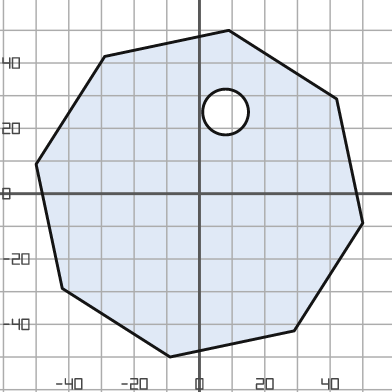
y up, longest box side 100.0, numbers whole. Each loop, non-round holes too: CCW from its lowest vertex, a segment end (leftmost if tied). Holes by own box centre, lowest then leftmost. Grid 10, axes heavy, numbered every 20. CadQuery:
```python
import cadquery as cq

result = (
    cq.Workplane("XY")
    .moveTo(-9.0, -50.0)
    .lineTo(29.0, -42.0)
    .lineTo(50.0, -9.0)
    .lineTo(42.0, 29.0)
    .lineTo(9.0, 50.0)
    .lineTo(-29.0, 42.0)
    .lineTo(-50.0, 9.0)
    .lineTo(-42.0, -29.0)
    .close()
    .moveTo(8.0, 25.0)
    .circle(7.0)
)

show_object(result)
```